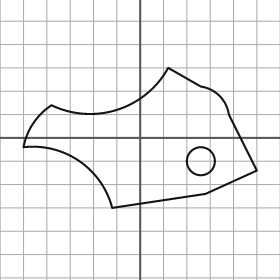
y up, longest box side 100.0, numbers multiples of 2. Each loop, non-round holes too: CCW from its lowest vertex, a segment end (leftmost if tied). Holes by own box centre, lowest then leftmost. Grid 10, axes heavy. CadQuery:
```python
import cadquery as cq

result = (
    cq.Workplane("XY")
    .moveTo(-12.0, -30.0)
    .lineTo(28.0, -24.0)
    .lineTo(50.0, -14.0)
    .lineTo(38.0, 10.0)
    .threePointArc((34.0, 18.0), (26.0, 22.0))
    .lineTo(12.0, 30.0)
    .threePointArc((-10.0, 12.0), (-38.0, 14.0))
    .threePointArc((-46.0, 6.0), (-50.0, -4.0))
    .threePointArc((-26.0, -10.0), (-12.0, -30.0))
    .close()
    .moveTo(26.0, -10.0)
    .circle(6.0)
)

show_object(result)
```